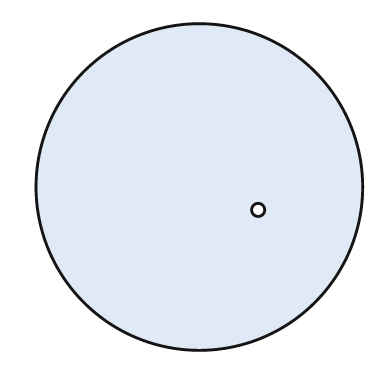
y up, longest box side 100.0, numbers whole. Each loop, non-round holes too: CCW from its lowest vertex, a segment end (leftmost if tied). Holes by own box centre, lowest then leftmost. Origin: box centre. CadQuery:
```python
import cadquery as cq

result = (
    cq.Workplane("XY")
    .moveTo(0.0, 0.0)
    .circle(50.0)
    .moveTo(18.0, -7.0)
    .circle(2.0)
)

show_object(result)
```